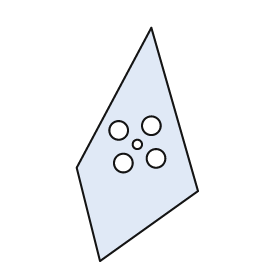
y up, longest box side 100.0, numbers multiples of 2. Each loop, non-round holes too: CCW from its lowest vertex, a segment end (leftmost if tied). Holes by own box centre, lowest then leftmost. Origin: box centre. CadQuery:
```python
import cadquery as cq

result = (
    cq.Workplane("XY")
    .moveTo(-16.0, -50.0)
    .lineTo(26.0, -20.0)
    .lineTo(6.0, 50.0)
    .lineTo(-26.0, -10.0)
    .close()
    .moveTo(-6.0, -8.0)
    .circle(4.0)
    .moveTo(8.0, -6.0)
    .circle(4.0)
    .moveTo(0.0, 0.0)
    .circle(2.0)
    .moveTo(-8.0, 6.0)
    .circle(4.0)
    .moveTo(6.0, 8.0)
    .circle(4.0)
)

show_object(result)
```